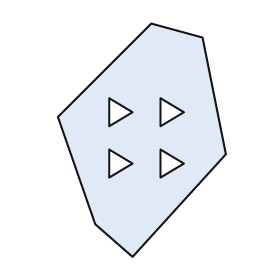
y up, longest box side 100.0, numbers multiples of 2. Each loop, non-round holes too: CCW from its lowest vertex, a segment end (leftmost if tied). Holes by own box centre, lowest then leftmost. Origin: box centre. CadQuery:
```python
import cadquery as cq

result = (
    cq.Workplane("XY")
    .moveTo(-4.0, -50.0)
    .lineTo(36.0, -6.0)
    .lineTo(26.0, 44.0)
    .lineTo(4.0, 50.0)
    .lineTo(-36.0, 10.0)
    .lineTo(-20.0, -36.0)
    .close()
    .moveTo(-14.0, -16.0)
    .lineTo(-4.0, -10.0)
    .lineTo(-14.0, -4.0)
    .close()
    .moveTo(8.0, -16.0)
    .lineTo(18.0, -10.0)
    .lineTo(8.0, -4.0)
    .close()
    .moveTo(-14.0, 6.0)
    .lineTo(-4.0, 12.0)
    .lineTo(-14.0, 18.0)
    .close()
    .moveTo(8.0, 6.0)
    .lineTo(18.0, 12.0)
    .lineTo(8.0, 18.0)
    .close()
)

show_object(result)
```